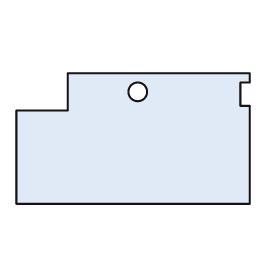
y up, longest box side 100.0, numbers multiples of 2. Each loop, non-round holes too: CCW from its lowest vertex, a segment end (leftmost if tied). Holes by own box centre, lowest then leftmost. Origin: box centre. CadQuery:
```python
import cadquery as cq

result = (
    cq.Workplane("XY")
    .moveTo(-50.0, -28.0)
    .lineTo(50.0, -28.0)
    .lineTo(50.0, 14.0)
    .lineTo(46.0, 14.0)
    .lineTo(46.0, 24.0)
    .lineTo(50.0, 24.0)
    .lineTo(50.0, 28.0)
    .lineTo(-28.0, 28.0)
    .lineTo(-28.0, 12.0)
    .lineTo(-50.0, 12.0)
    .close()
    .moveTo(2.0, 20.0)
    .circle(4.0)
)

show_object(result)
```